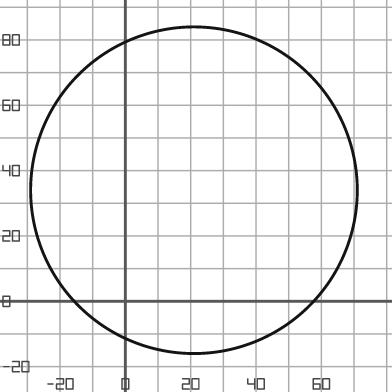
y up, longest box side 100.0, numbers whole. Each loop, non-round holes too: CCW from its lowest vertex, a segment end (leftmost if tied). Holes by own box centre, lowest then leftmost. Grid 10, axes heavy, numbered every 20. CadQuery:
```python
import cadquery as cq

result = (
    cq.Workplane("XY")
    .moveTo(21.0, 34.0)
    .circle(50.0)
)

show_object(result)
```